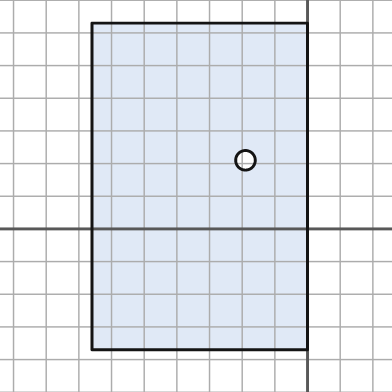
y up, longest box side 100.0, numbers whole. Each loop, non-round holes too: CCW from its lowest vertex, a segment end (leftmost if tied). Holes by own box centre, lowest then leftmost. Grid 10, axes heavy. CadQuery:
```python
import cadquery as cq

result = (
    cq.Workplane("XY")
    .moveTo(-66.0, -37.0)
    .lineTo(0.0, -37.0)
    .lineTo(0.0, 63.0)
    .lineTo(-66.0, 63.0)
    .close()
    .moveTo(-19.0, 21.0)
    .circle(3.0)
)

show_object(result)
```